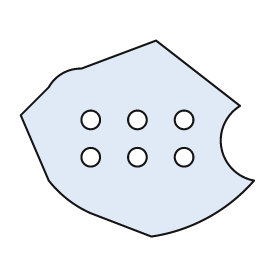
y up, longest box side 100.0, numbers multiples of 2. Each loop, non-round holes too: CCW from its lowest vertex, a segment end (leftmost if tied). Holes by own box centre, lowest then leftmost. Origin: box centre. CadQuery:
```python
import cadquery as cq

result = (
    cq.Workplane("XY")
    .moveTo(6.0, -42.0)
    .threePointArc((30.0, -34.0), (50.0, -18.0))
    .threePointArc((36.0, -4.0), (44.0, 14.0))
    .lineTo(8.0, 42.0)
    .lineTo(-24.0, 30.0)
    .threePointArc((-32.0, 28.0), (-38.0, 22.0))
    .lineTo(-50.0, 10.0)
    .lineTo(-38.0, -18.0)
    .threePointArc((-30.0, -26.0), (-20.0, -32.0))
    .close()
    .moveTo(-20.0, -8.0)
    .circle(4.0)
    .moveTo(0.0, -8.0)
    .circle(4.0)
    .moveTo(20.0, -8.0)
    .circle(4.0)
    .moveTo(-20.0, 8.0)
    .circle(4.0)
    .moveTo(0.0, 8.0)
    .circle(4.0)
    .moveTo(20.0, 8.0)
    .circle(4.0)
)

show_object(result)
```